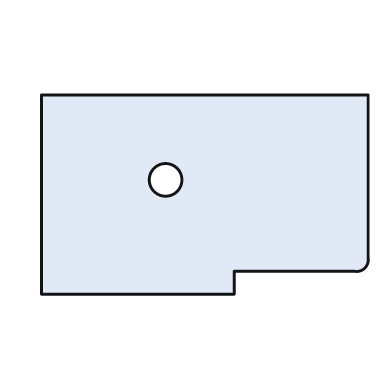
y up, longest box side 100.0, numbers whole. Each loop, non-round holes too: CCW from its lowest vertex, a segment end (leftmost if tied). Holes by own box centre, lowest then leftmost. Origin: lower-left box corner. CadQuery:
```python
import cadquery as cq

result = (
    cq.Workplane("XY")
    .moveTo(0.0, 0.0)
    .lineTo(59.0, 0.0)
    .lineTo(59.0, 7.0)
    .lineTo(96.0, 7.0)
    .threePointArc((99.0, 8.0), (100.0, 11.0))
    .lineTo(100.0, 61.0)
    .lineTo(0.0, 61.0)
    .close()
    .moveTo(38.0, 35.0)
    .circle(5.0)
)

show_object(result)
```